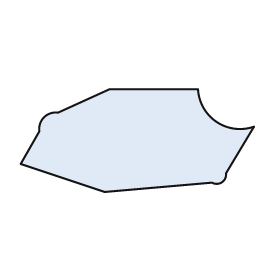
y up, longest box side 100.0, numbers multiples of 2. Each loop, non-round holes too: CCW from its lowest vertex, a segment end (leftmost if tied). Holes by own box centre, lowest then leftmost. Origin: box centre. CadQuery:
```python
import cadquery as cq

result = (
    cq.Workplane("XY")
    .moveTo(-14.0, -22.0)
    .lineTo(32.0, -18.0)
    .threePointArc((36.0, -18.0), (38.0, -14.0))
    .lineTo(50.0, 6.0)
    .threePointArc((34.0, 8.0), (26.0, 22.0))
    .lineTo(-12.0, 22.0)
    .lineTo(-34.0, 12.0)
    .threePointArc((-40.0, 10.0), (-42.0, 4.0))
    .lineTo(-50.0, -10.0)
    .close()
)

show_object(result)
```